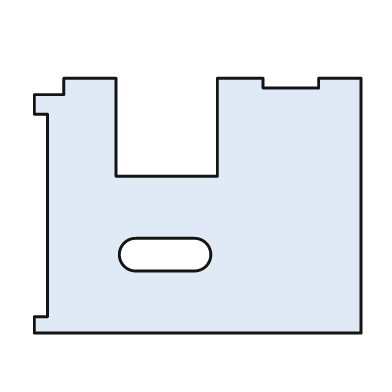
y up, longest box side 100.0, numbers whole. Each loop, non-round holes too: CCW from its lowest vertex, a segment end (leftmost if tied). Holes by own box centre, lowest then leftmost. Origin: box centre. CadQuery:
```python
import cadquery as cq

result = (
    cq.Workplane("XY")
    .moveTo(-50.0, -39.0)
    .lineTo(50.0, -39.0)
    .lineTo(50.0, 39.0)
    .lineTo(37.0, 39.0)
    .lineTo(37.0, 36.0)
    .lineTo(20.0, 36.0)
    .lineTo(20.0, 39.0)
    .lineTo(6.0, 39.0)
    .lineTo(6.0, 9.0)
    .lineTo(-25.0, 9.0)
    .lineTo(-25.0, 39.0)
    .lineTo(-41.0, 39.0)
    .lineTo(-41.0, 34.0)
    .lineTo(-50.0, 34.0)
    .lineTo(-50.0, 28.0)
    .lineTo(-46.0, 28.0)
    .lineTo(-46.0, -34.0)
    .lineTo(-50.0, -34.0)
    .close()
    .moveTo(-19.0, -20.0)
    .lineTo(-1.0, -20.0)
    .threePointArc((4.0, -15.0), (-1.0, -10.0))
    .lineTo(-19.0, -10.0)
    .threePointArc((-24.0, -15.0), (-19.0, -20.0))
    .close()
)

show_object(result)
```